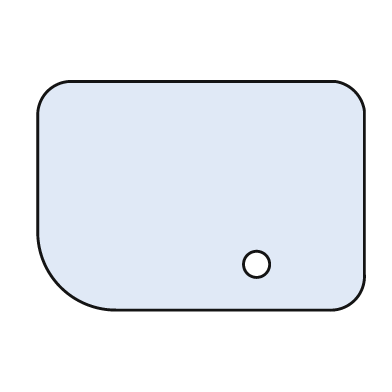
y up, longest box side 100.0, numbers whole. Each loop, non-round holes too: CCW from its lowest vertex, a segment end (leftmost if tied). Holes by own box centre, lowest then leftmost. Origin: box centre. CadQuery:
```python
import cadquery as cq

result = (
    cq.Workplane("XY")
    .moveTo(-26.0, -35.0)
    .lineTo(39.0, -35.0)
    .threePointArc((47.0, -32.0), (50.0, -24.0))
    .lineTo(50.0, 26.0)
    .threePointArc((47.0, 32.0), (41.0, 35.0))
    .lineTo(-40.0, 35.0)
    .threePointArc((-47.0, 32.0), (-50.0, 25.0))
    .lineTo(-50.0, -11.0)
    .threePointArc((-43.0, -28.0), (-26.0, -35.0))
    .close()
    .moveTo(17.0, -21.0)
    .circle(4.0)
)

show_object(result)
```